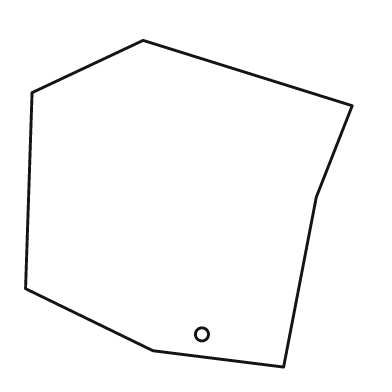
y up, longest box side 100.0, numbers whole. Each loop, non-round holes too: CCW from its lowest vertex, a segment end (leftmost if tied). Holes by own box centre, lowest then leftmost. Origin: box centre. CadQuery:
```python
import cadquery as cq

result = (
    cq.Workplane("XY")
    .moveTo(29.0, -50.0)
    .lineTo(39.0, 2.0)
    .lineTo(50.0, 30.0)
    .lineTo(-14.0, 50.0)
    .lineTo(-48.0, 34.0)
    .lineTo(-50.0, -26.0)
    .lineTo(-11.0, -45.0)
    .close()
    .moveTo(4.0, -40.0)
    .circle(2.0)
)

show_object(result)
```